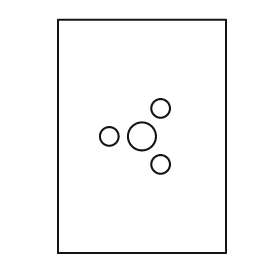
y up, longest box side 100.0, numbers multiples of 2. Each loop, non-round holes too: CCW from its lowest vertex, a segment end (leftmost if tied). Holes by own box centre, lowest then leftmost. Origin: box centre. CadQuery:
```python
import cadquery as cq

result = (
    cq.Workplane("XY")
    .moveTo(-36.0, -50.0)
    .lineTo(36.0, -50.0)
    .lineTo(36.0, 50.0)
    .lineTo(-36.0, 50.0)
    .close()
    .moveTo(8.0, -12.0)
    .circle(4.0)
    .moveTo(-14.0, 0.0)
    .circle(4.0)
    .moveTo(0.0, 0.0)
    .circle(6.0)
    .moveTo(8.0, 12.0)
    .circle(4.0)
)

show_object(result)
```